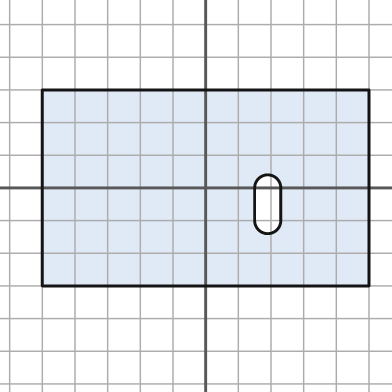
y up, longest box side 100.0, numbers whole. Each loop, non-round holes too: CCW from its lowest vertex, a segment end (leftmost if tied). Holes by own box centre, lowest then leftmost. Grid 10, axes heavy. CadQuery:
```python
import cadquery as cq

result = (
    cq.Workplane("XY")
    .moveTo(-50.0, -30.0)
    .lineTo(50.0, -30.0)
    .lineTo(50.0, 30.0)
    .lineTo(-50.0, 30.0)
    .close()
    .moveTo(15.0, -10.0)
    .threePointArc((19.0, -14.0), (23.0, -10.0))
    .lineTo(23.0, 0.0)
    .threePointArc((19.0, 4.0), (15.0, 0.0))
    .close()
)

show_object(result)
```